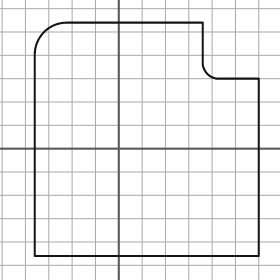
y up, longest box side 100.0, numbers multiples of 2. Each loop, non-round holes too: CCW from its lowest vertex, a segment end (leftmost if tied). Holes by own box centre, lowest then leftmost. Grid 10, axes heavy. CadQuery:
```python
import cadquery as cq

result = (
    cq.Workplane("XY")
    .moveTo(-36.0, -46.0)
    .lineTo(60.0, -46.0)
    .lineTo(60.0, 30.0)
    .lineTo(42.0, 30.0)
    .threePointArc((38.0, 32.0), (36.0, 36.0))
    .lineTo(36.0, 54.0)
    .lineTo(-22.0, 54.0)
    .threePointArc((-32.0, 50.0), (-36.0, 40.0))
    .close()
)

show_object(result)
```